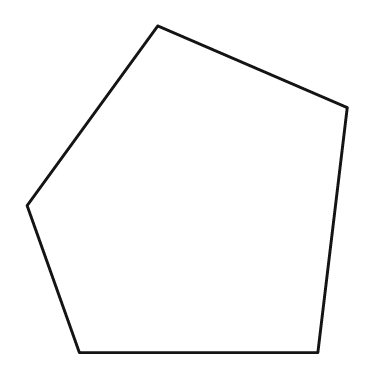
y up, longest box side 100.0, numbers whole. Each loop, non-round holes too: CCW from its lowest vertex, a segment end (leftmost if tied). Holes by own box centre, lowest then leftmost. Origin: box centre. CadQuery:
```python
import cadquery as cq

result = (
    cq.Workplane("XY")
    .moveTo(-33.0, -50.0)
    .lineTo(40.0, -50.0)
    .lineTo(49.0, 25.0)
    .lineTo(-9.0, 50.0)
    .lineTo(-49.0, -5.0)
    .close()
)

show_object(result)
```